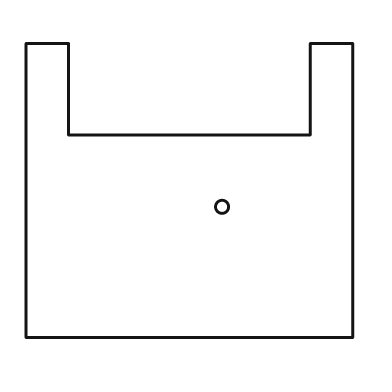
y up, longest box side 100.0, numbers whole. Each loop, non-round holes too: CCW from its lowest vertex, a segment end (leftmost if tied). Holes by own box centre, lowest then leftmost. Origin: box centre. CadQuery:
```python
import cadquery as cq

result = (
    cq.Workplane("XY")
    .moveTo(-50.0, -45.0)
    .lineTo(50.0, -45.0)
    .lineTo(50.0, 45.0)
    .lineTo(37.0, 45.0)
    .lineTo(37.0, 17.0)
    .lineTo(-37.0, 17.0)
    .lineTo(-37.0, 45.0)
    .lineTo(-50.0, 45.0)
    .close()
    .moveTo(10.0, -5.0)
    .circle(2.0)
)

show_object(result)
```